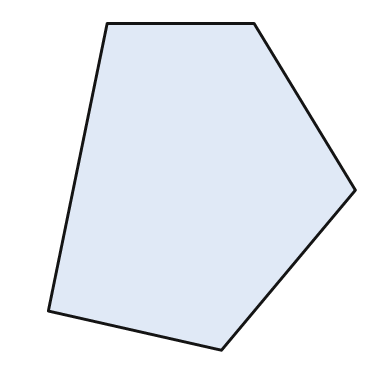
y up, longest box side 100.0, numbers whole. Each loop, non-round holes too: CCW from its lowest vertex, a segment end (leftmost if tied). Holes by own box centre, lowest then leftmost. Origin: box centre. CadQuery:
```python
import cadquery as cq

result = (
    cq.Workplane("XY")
    .moveTo(6.0, -50.0)
    .lineTo(47.0, -1.0)
    .lineTo(16.0, 50.0)
    .lineTo(-29.0, 50.0)
    .lineTo(-47.0, -38.0)
    .close()
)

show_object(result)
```